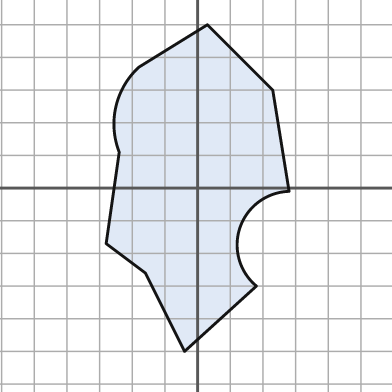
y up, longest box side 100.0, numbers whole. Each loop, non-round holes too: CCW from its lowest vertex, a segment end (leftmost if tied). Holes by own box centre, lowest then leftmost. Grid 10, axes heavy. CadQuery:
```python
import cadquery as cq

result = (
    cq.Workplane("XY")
    .moveTo(-4.0, -50.0)
    .lineTo(18.0, -30.0)
    .threePointArc((13.0, -12.0), (28.0, -1.0))
    .lineTo(23.0, 30.0)
    .lineTo(3.0, 50.0)
    .lineTo(-18.0, 37.0)
    .threePointArc((-25.0, 25.0), (-24.0, 11.0))
    .lineTo(-28.0, -17.0)
    .lineTo(-16.0, -26.0)
    .close()
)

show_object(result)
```